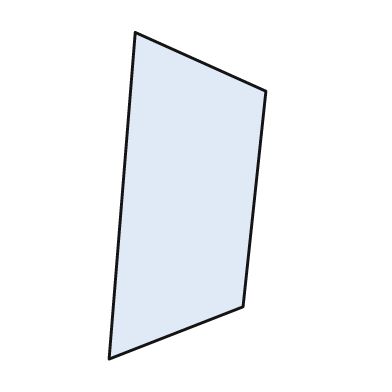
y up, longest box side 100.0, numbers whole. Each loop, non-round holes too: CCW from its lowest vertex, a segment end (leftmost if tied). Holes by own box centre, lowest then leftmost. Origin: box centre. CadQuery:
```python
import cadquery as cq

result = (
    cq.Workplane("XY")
    .moveTo(-24.0, -50.0)
    .lineTo(17.0, -34.0)
    .lineTo(24.0, 32.0)
    .lineTo(-16.0, 50.0)
    .close()
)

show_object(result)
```